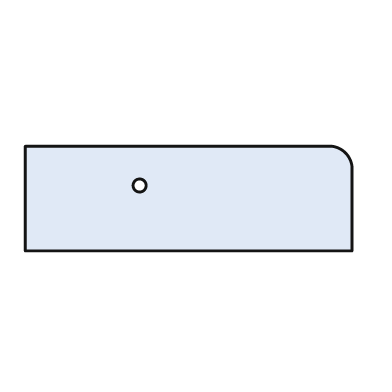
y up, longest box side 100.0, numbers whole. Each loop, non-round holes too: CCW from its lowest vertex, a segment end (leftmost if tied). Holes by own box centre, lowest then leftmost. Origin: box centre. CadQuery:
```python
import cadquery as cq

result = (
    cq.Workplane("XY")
    .moveTo(-50.0, -16.0)
    .lineTo(50.0, -16.0)
    .lineTo(50.0, 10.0)
    .threePointArc((48.0, 14.0), (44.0, 16.0))
    .lineTo(-50.0, 16.0)
    .close()
    .moveTo(-15.0, 4.0)
    .circle(2.0)
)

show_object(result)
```